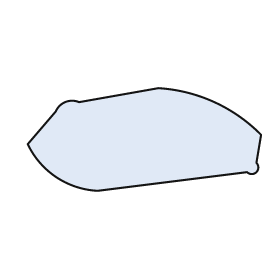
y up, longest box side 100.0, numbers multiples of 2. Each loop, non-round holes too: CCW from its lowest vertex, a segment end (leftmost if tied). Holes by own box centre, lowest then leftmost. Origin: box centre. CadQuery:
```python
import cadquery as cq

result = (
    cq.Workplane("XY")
    .moveTo(-20.0, -22.0)
    .lineTo(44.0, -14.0)
    .threePointArc((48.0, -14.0), (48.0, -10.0))
    .lineTo(50.0, 2.0)
    .threePointArc((30.0, 16.0), (6.0, 22.0))
    .lineTo(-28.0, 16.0)
    .threePointArc((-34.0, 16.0), (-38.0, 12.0))
    .lineTo(-50.0, -2.0)
    .threePointArc((-38.0, -16.0), (-20.0, -22.0))
    .close()
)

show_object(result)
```